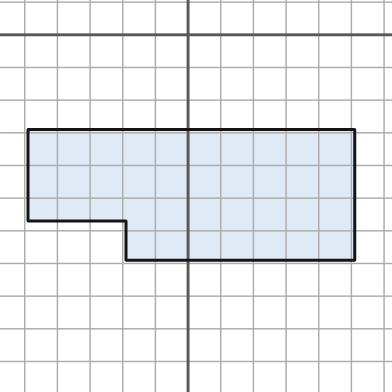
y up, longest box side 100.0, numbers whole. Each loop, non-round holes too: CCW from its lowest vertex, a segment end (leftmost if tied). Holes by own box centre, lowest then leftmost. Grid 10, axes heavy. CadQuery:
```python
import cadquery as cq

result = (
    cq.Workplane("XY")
    .moveTo(-19.0, -69.0)
    .lineTo(51.0, -69.0)
    .lineTo(51.0, -29.0)
    .lineTo(-49.0, -29.0)
    .lineTo(-49.0, -57.0)
    .lineTo(-19.0, -57.0)
    .close()
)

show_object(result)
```